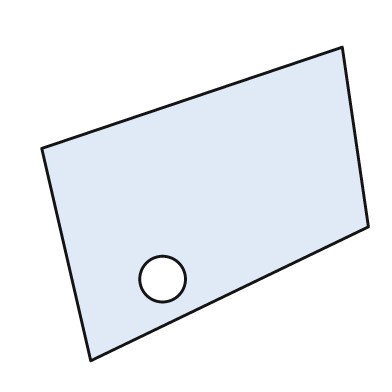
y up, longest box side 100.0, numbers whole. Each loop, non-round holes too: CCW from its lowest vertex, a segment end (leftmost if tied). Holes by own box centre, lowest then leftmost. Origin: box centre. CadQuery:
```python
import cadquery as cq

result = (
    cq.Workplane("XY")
    .moveTo(-35.0, -48.0)
    .lineTo(50.0, -7.0)
    .lineTo(42.0, 48.0)
    .lineTo(-50.0, 17.0)
    .close()
    .moveTo(-13.0, -23.0)
    .circle(7.0)
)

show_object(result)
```